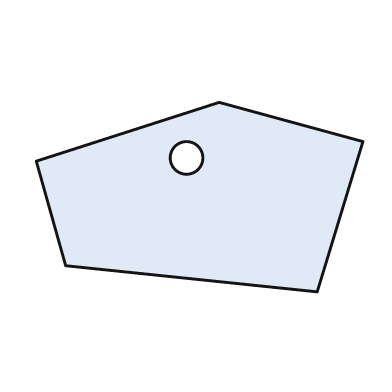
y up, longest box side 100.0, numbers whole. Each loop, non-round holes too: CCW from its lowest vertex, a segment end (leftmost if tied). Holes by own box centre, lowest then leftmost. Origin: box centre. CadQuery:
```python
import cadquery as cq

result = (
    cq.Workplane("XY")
    .moveTo(36.0, -29.0)
    .lineTo(50.0, 17.0)
    .lineTo(6.0, 29.0)
    .lineTo(-50.0, 11.0)
    .lineTo(-41.0, -21.0)
    .close()
    .moveTo(-4.0, 12.0)
    .circle(5.0)
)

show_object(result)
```